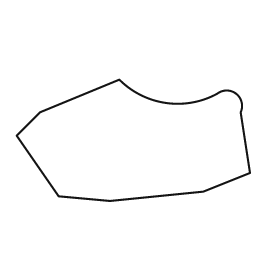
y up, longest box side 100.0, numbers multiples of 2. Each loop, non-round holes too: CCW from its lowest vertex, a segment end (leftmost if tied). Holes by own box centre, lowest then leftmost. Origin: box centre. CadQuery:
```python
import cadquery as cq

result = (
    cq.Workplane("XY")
    .moveTo(-10.0, -26.0)
    .lineTo(30.0, -22.0)
    .lineTo(50.0, -14.0)
    .lineTo(46.0, 12.0)
    .threePointArc((44.0, 20.0), (36.0, 20.0))
    .threePointArc((14.0, 16.0), (-6.0, 26.0))
    .lineTo(-40.0, 12.0)
    .lineTo(-50.0, 2.0)
    .lineTo(-32.0, -24.0)
    .close()
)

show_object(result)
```